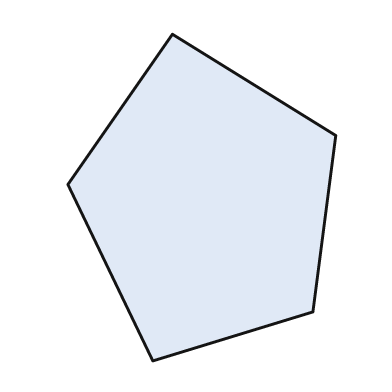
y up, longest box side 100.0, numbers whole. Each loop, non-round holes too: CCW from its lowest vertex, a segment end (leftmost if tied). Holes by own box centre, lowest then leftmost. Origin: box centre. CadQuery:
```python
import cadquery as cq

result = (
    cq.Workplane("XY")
    .moveTo(-15.0, -50.0)
    .lineTo(34.0, -35.0)
    .lineTo(41.0, 19.0)
    .lineTo(-9.0, 50.0)
    .lineTo(-41.0, 4.0)
    .close()
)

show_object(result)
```